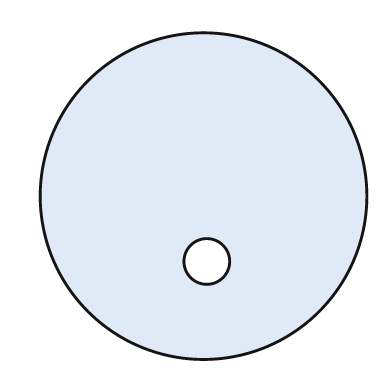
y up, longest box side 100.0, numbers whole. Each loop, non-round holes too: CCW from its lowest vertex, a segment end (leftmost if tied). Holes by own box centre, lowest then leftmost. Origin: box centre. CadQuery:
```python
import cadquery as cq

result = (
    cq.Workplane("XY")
    .moveTo(0.0, 0.0)
    .circle(50.0)
    .moveTo(1.0, -20.0)
    .circle(7.0)
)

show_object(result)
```